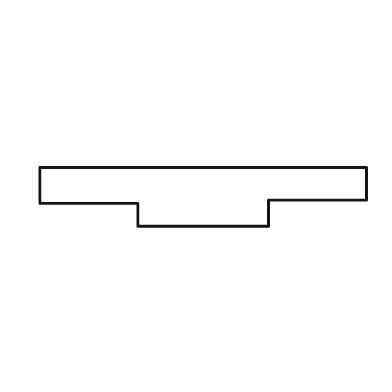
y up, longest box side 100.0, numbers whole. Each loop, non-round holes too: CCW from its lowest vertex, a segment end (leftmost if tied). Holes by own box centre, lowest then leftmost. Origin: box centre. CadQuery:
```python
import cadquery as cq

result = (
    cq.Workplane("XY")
    .moveTo(-20.0, -9.0)
    .lineTo(20.0, -9.0)
    .lineTo(20.0, -1.0)
    .lineTo(50.0, -1.0)
    .lineTo(50.0, 9.0)
    .lineTo(-50.0, 9.0)
    .lineTo(-50.0, -2.0)
    .lineTo(-20.0, -2.0)
    .close()
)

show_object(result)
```